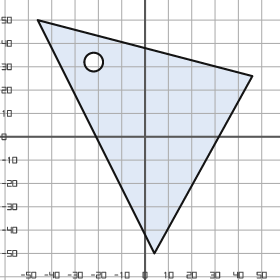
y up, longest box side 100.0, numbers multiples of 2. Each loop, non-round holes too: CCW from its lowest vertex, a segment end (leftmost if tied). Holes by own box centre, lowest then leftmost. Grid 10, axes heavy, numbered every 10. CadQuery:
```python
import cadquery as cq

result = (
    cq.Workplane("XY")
    .moveTo(4.0, -50.0)
    .lineTo(46.0, 26.0)
    .lineTo(-46.0, 50.0)
    .close()
    .moveTo(-22.0, 32.0)
    .circle(4.0)
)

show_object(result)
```